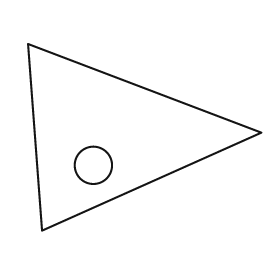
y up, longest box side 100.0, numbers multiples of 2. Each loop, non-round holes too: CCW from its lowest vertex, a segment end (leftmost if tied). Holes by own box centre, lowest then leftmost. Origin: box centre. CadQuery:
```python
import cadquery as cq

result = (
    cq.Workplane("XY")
    .moveTo(-44.0, -40.0)
    .lineTo(50.0, 2.0)
    .lineTo(-50.0, 40.0)
    .close()
    .moveTo(-22.0, -12.0)
    .circle(8.0)
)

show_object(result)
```